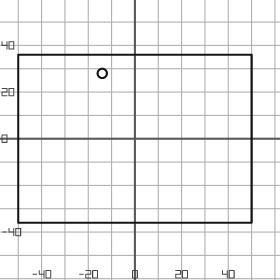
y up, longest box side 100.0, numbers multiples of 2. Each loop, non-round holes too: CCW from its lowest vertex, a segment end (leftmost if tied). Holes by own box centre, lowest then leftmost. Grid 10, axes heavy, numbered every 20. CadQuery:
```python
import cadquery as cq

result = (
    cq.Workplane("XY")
    .moveTo(-50.0, -36.0)
    .lineTo(50.0, -36.0)
    .lineTo(50.0, 36.0)
    .lineTo(-50.0, 36.0)
    .close()
    .moveTo(-14.0, 28.0)
    .circle(2.0)
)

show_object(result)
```